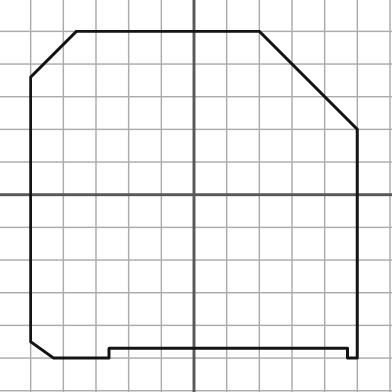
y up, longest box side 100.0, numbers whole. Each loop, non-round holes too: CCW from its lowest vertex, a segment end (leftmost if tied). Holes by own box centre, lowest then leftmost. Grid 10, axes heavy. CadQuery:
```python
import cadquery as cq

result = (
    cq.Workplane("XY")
    .moveTo(-43.0, -50.0)
    .lineTo(-26.0, -50.0)
    .lineTo(-26.0, -47.0)
    .lineTo(47.0, -47.0)
    .lineTo(47.0, -50.0)
    .lineTo(50.0, -50.0)
    .lineTo(50.0, 20.0)
    .lineTo(20.0, 50.0)
    .lineTo(-36.0, 50.0)
    .lineTo(-50.0, 36.0)
    .lineTo(-50.0, -45.0)
    .close()
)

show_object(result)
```